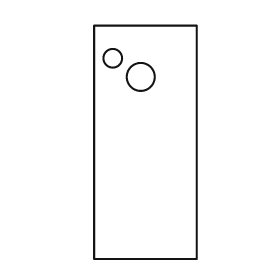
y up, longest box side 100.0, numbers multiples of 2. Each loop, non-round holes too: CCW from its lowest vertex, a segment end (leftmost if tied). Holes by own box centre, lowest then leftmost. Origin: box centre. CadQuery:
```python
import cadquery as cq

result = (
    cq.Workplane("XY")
    .moveTo(-22.0, -50.0)
    .lineTo(22.0, -50.0)
    .lineTo(22.0, 50.0)
    .lineTo(-22.0, 50.0)
    .close()
    .moveTo(-2.0, 28.0)
    .circle(6.0)
    .moveTo(-14.0, 36.0)
    .circle(4.0)
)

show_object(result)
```